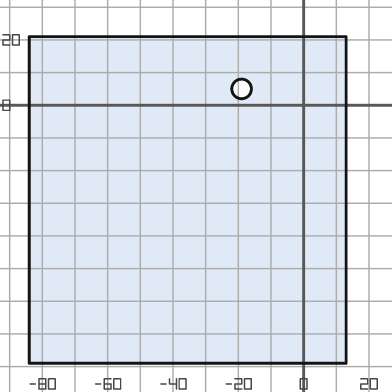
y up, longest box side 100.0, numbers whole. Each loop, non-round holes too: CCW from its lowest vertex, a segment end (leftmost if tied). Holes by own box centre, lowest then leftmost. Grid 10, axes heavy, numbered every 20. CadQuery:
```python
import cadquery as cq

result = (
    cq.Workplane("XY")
    .moveTo(-84.0, -79.0)
    .lineTo(13.0, -79.0)
    .lineTo(13.0, 21.0)
    .lineTo(-84.0, 21.0)
    .close()
    .moveTo(-19.0, 5.0)
    .circle(3.0)
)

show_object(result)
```